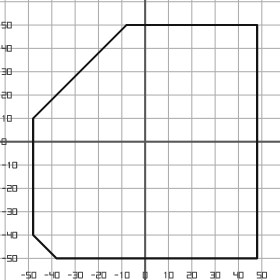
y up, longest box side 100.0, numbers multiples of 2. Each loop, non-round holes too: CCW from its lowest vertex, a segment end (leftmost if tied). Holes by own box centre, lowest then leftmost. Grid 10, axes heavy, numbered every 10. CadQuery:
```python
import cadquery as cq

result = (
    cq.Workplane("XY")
    .moveTo(-38.0, -50.0)
    .lineTo(48.0, -50.0)
    .lineTo(48.0, 50.0)
    .lineTo(-8.0, 50.0)
    .lineTo(-48.0, 10.0)
    .lineTo(-48.0, -40.0)
    .close()
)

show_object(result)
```